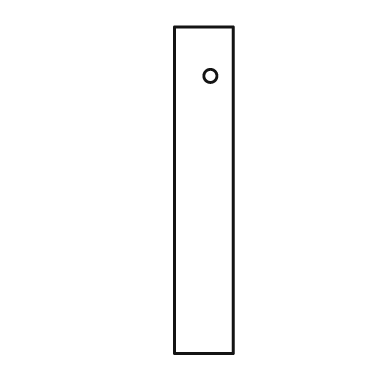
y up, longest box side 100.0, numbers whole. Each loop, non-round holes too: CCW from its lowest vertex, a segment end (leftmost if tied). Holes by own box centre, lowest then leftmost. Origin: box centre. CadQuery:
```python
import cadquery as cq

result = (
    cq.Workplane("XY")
    .moveTo(-9.0, -50.0)
    .lineTo(9.0, -50.0)
    .lineTo(9.0, 50.0)
    .lineTo(-9.0, 50.0)
    .close()
    .moveTo(2.0, 35.0)
    .circle(2.0)
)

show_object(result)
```